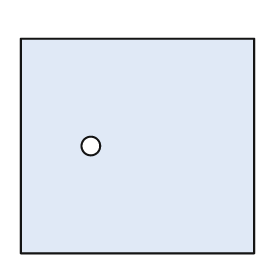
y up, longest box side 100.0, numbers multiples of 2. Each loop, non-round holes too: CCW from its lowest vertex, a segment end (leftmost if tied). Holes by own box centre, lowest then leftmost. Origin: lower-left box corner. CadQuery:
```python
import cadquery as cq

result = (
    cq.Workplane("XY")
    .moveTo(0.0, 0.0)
    .lineTo(100.0, 0.0)
    .lineTo(100.0, 92.0)
    .lineTo(0.0, 92.0)
    .close()
    .moveTo(30.0, 46.0)
    .circle(4.0)
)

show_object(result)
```